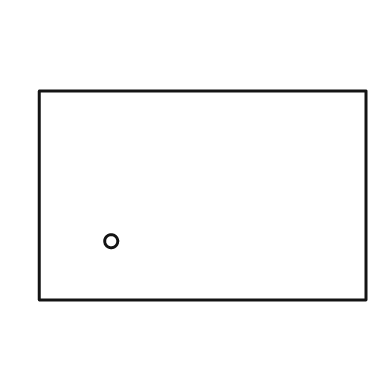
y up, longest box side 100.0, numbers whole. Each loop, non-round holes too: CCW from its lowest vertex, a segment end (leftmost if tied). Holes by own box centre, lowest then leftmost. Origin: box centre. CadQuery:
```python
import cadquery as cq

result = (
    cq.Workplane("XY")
    .moveTo(-50.0, -32.0)
    .lineTo(50.0, -32.0)
    .lineTo(50.0, 32.0)
    .lineTo(-50.0, 32.0)
    .close()
    .moveTo(-28.0, -14.0)
    .circle(2.0)
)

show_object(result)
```